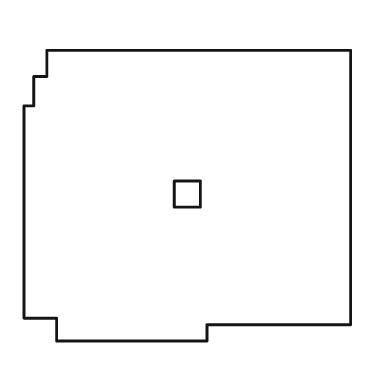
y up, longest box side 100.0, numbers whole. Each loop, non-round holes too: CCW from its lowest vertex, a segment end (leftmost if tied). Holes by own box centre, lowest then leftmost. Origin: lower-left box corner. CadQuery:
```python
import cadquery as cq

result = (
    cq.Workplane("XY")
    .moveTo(10.0, 0.0)
    .lineTo(56.0, 0.0)
    .lineTo(56.0, 5.0)
    .lineTo(100.0, 5.0)
    .lineTo(100.0, 89.0)
    .lineTo(7.0, 89.0)
    .lineTo(7.0, 81.0)
    .lineTo(3.0, 81.0)
    .lineTo(3.0, 72.0)
    .lineTo(0.0, 72.0)
    .lineTo(0.0, 7.0)
    .lineTo(10.0, 7.0)
    .close()
    .moveTo(46.0, 41.0)
    .lineTo(54.0, 41.0)
    .lineTo(54.0, 49.0)
    .lineTo(46.0, 49.0)
    .close()
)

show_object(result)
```